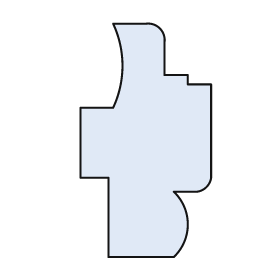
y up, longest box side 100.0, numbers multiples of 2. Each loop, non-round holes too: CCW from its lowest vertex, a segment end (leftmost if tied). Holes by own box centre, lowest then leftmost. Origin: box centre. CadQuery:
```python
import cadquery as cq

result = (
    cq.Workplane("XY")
    .moveTo(-16.0, -50.0)
    .lineTo(12.0, -50.0)
    .threePointArc((18.0, -36.0), (12.0, -22.0))
    .lineTo(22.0, -22.0)
    .threePointArc((26.0, -20.0), (28.0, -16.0))
    .lineTo(28.0, 24.0)
    .lineTo(18.0, 24.0)
    .lineTo(18.0, 28.0)
    .lineTo(8.0, 28.0)
    .lineTo(8.0, 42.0)
    .threePointArc((6.0, 48.0), (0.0, 50.0))
    .lineTo(-14.0, 50.0)
    .threePointArc((-10.0, 32.0), (-14.0, 14.0))
    .lineTo(-28.0, 14.0)
    .lineTo(-28.0, -16.0)
    .lineTo(-16.0, -16.0)
    .close()
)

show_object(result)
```